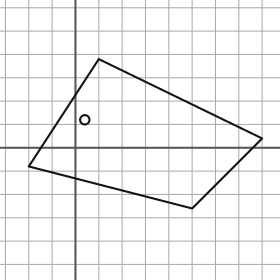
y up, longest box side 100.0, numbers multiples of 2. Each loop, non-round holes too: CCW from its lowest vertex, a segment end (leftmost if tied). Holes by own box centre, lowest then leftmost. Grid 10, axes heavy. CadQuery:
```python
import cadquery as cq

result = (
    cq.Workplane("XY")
    .moveTo(50.0, -26.0)
    .lineTo(80.0, 4.0)
    .lineTo(10.0, 38.0)
    .lineTo(-20.0, -8.0)
    .close()
    .moveTo(4.0, 12.0)
    .circle(2.0)
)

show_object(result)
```